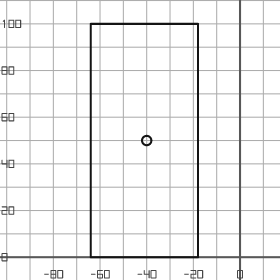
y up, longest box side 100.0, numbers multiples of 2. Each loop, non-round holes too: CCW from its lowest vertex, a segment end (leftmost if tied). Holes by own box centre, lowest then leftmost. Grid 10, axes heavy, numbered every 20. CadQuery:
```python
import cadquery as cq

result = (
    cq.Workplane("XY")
    .moveTo(-64.0, 0.0)
    .lineTo(-18.0, 0.0)
    .lineTo(-18.0, 100.0)
    .lineTo(-64.0, 100.0)
    .close()
    .moveTo(-40.0, 50.0)
    .circle(2.0)
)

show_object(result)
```